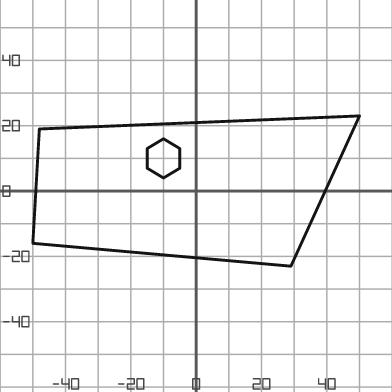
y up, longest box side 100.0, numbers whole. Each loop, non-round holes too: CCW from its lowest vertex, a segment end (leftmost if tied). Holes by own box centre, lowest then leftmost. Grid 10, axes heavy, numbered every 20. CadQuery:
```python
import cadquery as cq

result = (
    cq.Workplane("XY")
    .moveTo(29.0, -23.0)
    .lineTo(50.0, 23.0)
    .lineTo(-48.0, 19.0)
    .lineTo(-50.0, -16.0)
    .close()
    .moveTo(-10.0, 4.0)
    .lineTo(-5.0, 7.0)
    .lineTo(-5.0, 13.0)
    .lineTo(-10.0, 16.0)
    .lineTo(-15.0, 13.0)
    .lineTo(-15.0, 7.0)
    .close()
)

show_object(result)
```